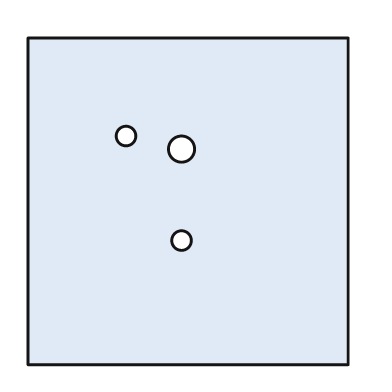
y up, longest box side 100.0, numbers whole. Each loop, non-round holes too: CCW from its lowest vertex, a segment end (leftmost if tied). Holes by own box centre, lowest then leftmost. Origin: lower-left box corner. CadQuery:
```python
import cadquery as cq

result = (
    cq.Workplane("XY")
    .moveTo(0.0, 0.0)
    .lineTo(98.0, 0.0)
    .lineTo(98.0, 100.0)
    .lineTo(0.0, 100.0)
    .close()
    .moveTo(47.0, 38.0)
    .circle(3.0)
    .moveTo(47.0, 66.0)
    .circle(4.0)
    .moveTo(30.0, 70.0)
    .circle(3.0)
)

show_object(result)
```